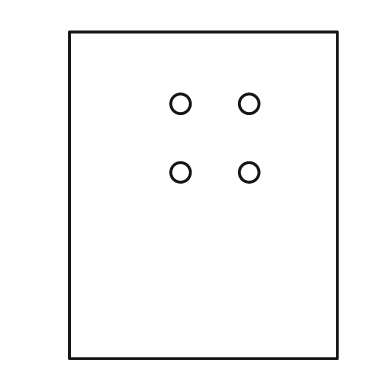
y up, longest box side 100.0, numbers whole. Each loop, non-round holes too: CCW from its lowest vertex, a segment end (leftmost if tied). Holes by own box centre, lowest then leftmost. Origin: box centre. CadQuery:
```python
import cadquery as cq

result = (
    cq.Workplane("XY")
    .moveTo(-41.0, -50.0)
    .lineTo(41.0, -50.0)
    .lineTo(41.0, 50.0)
    .lineTo(-41.0, 50.0)
    .close()
    .moveTo(-7.0, 7.0)
    .circle(3.0)
    .moveTo(14.0, 7.0)
    .circle(3.0)
    .moveTo(-7.0, 28.0)
    .circle(3.0)
    .moveTo(14.0, 28.0)
    .circle(3.0)
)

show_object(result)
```